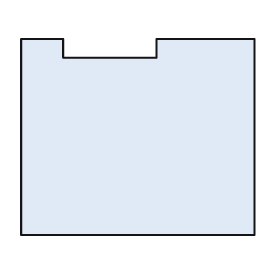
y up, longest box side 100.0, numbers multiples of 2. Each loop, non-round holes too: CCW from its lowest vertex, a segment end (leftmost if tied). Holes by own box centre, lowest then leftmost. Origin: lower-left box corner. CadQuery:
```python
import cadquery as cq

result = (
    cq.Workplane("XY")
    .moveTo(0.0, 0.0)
    .lineTo(100.0, 0.0)
    .lineTo(100.0, 84.0)
    .lineTo(58.0, 84.0)
    .lineTo(58.0, 76.0)
    .lineTo(18.0, 76.0)
    .lineTo(18.0, 84.0)
    .lineTo(0.0, 84.0)
    .close()
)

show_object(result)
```